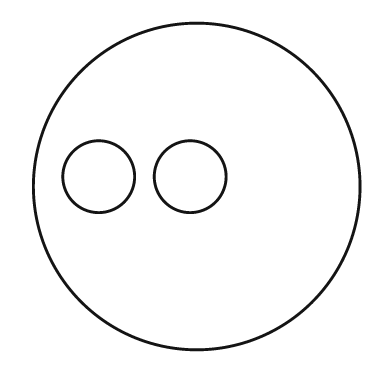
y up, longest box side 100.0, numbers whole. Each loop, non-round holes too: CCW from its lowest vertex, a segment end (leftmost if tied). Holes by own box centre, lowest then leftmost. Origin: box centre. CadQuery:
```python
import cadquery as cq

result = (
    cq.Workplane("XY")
    .moveTo(0.0, 0.0)
    .circle(50.0)
    .moveTo(-30.0, 3.0)
    .circle(11.0)
    .moveTo(-2.0, 3.0)
    .circle(11.0)
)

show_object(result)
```